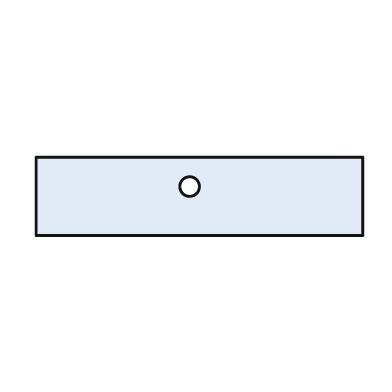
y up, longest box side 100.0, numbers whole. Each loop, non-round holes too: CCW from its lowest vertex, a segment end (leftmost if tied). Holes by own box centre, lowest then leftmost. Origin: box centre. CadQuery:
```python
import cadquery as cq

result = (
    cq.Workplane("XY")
    .moveTo(-50.0, -12.0)
    .lineTo(50.0, -12.0)
    .lineTo(50.0, 12.0)
    .lineTo(-50.0, 12.0)
    .close()
    .moveTo(-3.0, 3.0)
    .circle(3.0)
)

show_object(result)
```